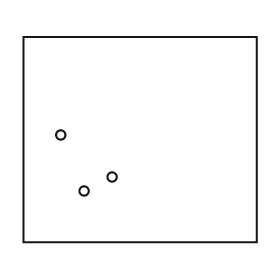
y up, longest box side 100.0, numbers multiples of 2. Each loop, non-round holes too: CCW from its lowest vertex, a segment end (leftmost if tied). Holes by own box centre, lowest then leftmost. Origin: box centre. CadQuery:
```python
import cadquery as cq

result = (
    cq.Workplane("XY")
    .moveTo(-50.0, -44.0)
    .lineTo(50.0, -44.0)
    .lineTo(50.0, 44.0)
    .lineTo(-50.0, 44.0)
    .close()
    .moveTo(-24.0, -22.0)
    .circle(2.0)
    .moveTo(-12.0, -16.0)
    .circle(2.0)
    .moveTo(-34.0, 2.0)
    .circle(2.0)
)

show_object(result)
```